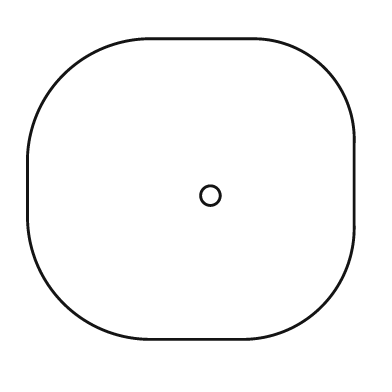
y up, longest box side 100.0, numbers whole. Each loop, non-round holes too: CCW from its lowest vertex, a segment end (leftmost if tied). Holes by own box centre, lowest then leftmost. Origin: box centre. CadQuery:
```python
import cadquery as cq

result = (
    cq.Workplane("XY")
    .moveTo(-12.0, -46.0)
    .lineTo(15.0, -46.0)
    .threePointArc((40.0, -36.0), (50.0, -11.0))
    .lineTo(50.0, 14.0)
    .threePointArc((41.0, 37.0), (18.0, 46.0))
    .lineTo(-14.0, 46.0)
    .threePointArc((-39.0, 35.0), (-50.0, 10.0))
    .lineTo(-50.0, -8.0)
    .threePointArc((-39.0, -35.0), (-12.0, -46.0))
    .close()
    .moveTo(6.0, -2.0)
    .circle(3.0)
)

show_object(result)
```